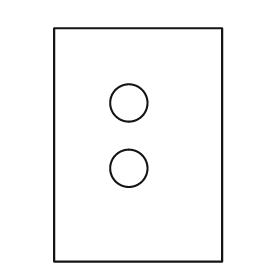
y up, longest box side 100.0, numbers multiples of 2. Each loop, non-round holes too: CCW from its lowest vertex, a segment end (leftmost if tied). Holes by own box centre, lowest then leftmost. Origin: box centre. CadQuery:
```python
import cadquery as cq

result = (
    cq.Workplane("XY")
    .moveTo(-36.0, -50.0)
    .lineTo(36.0, -50.0)
    .lineTo(36.0, 50.0)
    .lineTo(-36.0, 50.0)
    .close()
    .moveTo(-4.0, -10.0)
    .circle(8.0)
    .moveTo(-4.0, 18.0)
    .circle(8.0)
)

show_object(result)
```